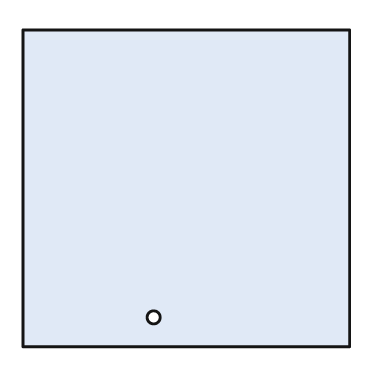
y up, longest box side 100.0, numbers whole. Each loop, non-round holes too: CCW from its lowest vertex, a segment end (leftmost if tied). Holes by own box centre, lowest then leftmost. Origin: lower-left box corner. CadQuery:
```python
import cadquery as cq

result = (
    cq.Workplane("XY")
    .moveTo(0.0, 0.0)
    .lineTo(100.0, 0.0)
    .lineTo(100.0, 97.0)
    .lineTo(0.0, 97.0)
    .close()
    .moveTo(40.0, 9.0)
    .circle(2.0)
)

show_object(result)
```